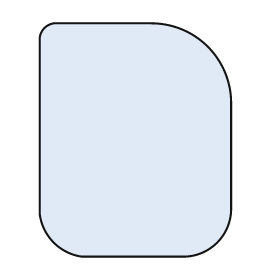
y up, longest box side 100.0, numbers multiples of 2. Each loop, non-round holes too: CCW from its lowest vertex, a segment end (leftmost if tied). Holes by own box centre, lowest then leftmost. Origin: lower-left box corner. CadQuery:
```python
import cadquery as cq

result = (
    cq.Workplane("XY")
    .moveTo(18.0, 0.0)
    .lineTo(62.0, 0.0)
    .threePointArc((76.0, 6.0), (82.0, 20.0))
    .lineTo(82.0, 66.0)
    .threePointArc((72.0, 90.0), (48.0, 100.0))
    .lineTo(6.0, 100.0)
    .threePointArc((2.0, 98.0), (0.0, 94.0))
    .lineTo(0.0, 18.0)
    .threePointArc((6.0, 6.0), (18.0, 0.0))
    .close()
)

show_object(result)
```